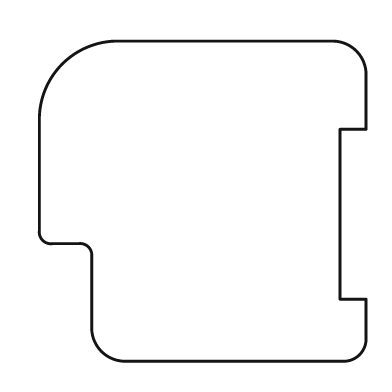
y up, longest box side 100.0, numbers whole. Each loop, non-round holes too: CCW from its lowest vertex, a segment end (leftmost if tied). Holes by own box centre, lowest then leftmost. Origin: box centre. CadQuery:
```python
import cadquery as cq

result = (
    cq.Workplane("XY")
    .moveTo(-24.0, -49.0)
    .lineTo(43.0, -49.0)
    .threePointArc((48.0, -47.0), (50.0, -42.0))
    .lineTo(50.0, -30.0)
    .lineTo(42.0, -30.0)
    .lineTo(42.0, 22.0)
    .lineTo(50.0, 22.0)
    .lineTo(50.0, 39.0)
    .threePointArc((47.0, 46.0), (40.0, 49.0))
    .lineTo(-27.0, 49.0)
    .threePointArc((-43.0, 42.0), (-50.0, 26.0))
    .lineTo(-50.0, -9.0)
    .threePointArc((-49.0, -12.0), (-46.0, -13.0))
    .lineTo(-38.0, -13.0)
    .threePointArc((-35.0, -14.0), (-34.0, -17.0))
    .lineTo(-34.0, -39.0)
    .threePointArc((-31.0, -46.0), (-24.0, -49.0))
    .close()
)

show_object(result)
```